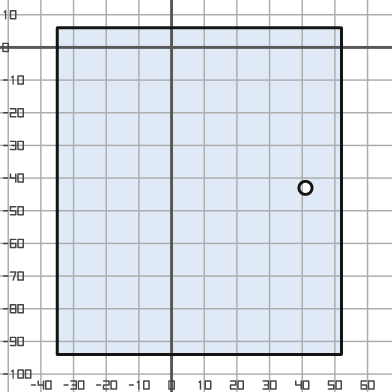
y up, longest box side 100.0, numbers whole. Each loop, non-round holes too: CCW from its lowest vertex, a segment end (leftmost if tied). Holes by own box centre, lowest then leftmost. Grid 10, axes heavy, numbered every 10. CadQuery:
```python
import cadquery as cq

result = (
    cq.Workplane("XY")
    .moveTo(-35.0, -94.0)
    .lineTo(52.0, -94.0)
    .lineTo(52.0, 6.0)
    .lineTo(-35.0, 6.0)
    .close()
    .moveTo(41.0, -43.0)
    .circle(2.0)
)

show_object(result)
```